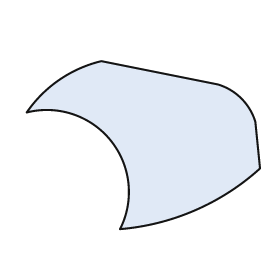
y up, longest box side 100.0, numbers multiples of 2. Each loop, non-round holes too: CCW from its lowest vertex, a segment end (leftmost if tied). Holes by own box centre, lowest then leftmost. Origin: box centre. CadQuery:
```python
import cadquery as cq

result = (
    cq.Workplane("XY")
    .moveTo(-10.0, -36.0)
    .threePointArc((22.0, -28.0), (50.0, -10.0))
    .lineTo(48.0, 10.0)
    .threePointArc((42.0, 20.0), (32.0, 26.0))
    .lineTo(-18.0, 36.0)
    .threePointArc((-36.0, 28.0), (-50.0, 14.0))
    .threePointArc((-14.0, 2.0), (-10.0, -36.0))
    .close()
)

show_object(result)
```